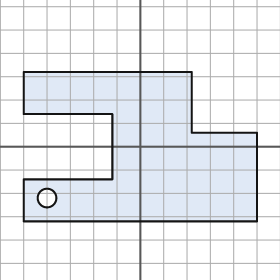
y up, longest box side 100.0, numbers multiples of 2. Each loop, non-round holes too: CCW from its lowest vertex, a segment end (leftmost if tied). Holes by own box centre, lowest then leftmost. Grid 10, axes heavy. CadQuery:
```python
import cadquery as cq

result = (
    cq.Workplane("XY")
    .moveTo(-50.0, -32.0)
    .lineTo(50.0, -32.0)
    .lineTo(50.0, 6.0)
    .lineTo(22.0, 6.0)
    .lineTo(22.0, 32.0)
    .lineTo(-50.0, 32.0)
    .lineTo(-50.0, 14.0)
    .lineTo(-12.0, 14.0)
    .lineTo(-12.0, -14.0)
    .lineTo(-50.0, -14.0)
    .close()
    .moveTo(-40.0, -22.0)
    .circle(4.0)
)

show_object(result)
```